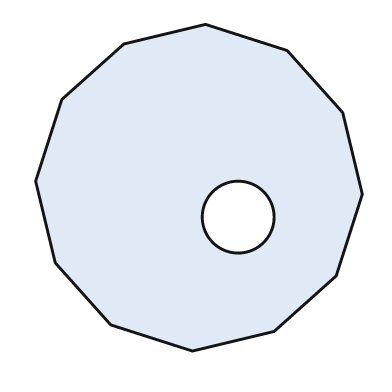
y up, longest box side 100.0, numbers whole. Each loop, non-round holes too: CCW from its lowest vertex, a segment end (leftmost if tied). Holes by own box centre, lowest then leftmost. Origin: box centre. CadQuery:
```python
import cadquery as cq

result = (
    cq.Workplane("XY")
    .moveTo(-2.0, -50.0)
    .lineTo(23.0, -44.0)
    .lineTo(42.0, -27.0)
    .lineTo(50.0, -2.0)
    .lineTo(44.0, 23.0)
    .lineTo(27.0, 42.0)
    .lineTo(2.0, 50.0)
    .lineTo(-23.0, 44.0)
    .lineTo(-42.0, 27.0)
    .lineTo(-50.0, 2.0)
    .lineTo(-44.0, -23.0)
    .lineTo(-27.0, -42.0)
    .close()
    .moveTo(12.0, -9.0)
    .circle(11.0)
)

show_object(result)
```